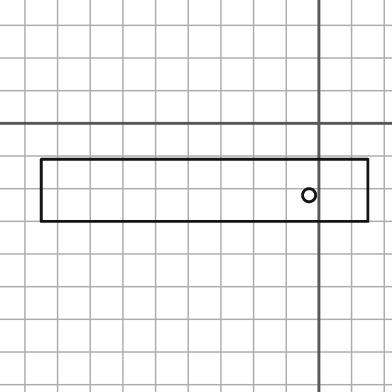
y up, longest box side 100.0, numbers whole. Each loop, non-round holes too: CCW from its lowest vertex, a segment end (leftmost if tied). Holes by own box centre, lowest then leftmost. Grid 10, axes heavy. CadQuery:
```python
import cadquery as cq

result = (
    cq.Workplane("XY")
    .moveTo(-85.0, -30.0)
    .lineTo(15.0, -30.0)
    .lineTo(15.0, -11.0)
    .lineTo(-85.0, -11.0)
    .close()
    .moveTo(-3.0, -22.0)
    .circle(2.0)
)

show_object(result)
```